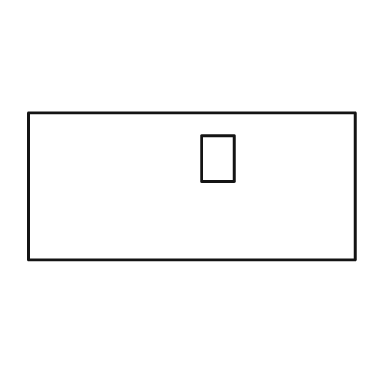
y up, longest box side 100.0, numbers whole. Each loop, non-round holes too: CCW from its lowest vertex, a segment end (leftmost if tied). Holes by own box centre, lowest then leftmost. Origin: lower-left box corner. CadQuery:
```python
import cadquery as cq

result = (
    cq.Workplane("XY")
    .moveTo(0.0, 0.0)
    .lineTo(100.0, 0.0)
    .lineTo(100.0, 45.0)
    .lineTo(0.0, 45.0)
    .close()
    .moveTo(53.0, 24.0)
    .lineTo(63.0, 24.0)
    .lineTo(63.0, 38.0)
    .lineTo(53.0, 38.0)
    .close()
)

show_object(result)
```